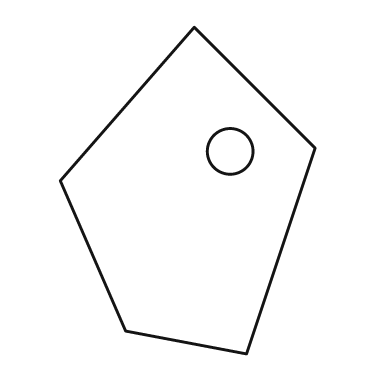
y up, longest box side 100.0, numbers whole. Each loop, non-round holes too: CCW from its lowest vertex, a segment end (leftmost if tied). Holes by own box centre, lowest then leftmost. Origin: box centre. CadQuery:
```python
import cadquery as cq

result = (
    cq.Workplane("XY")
    .moveTo(18.0, -50.0)
    .lineTo(39.0, 13.0)
    .lineTo(2.0, 50.0)
    .lineTo(-39.0, 3.0)
    .lineTo(-19.0, -43.0)
    .close()
    .moveTo(13.0, 12.0)
    .circle(7.0)
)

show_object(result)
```